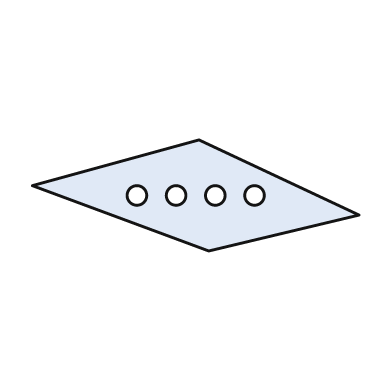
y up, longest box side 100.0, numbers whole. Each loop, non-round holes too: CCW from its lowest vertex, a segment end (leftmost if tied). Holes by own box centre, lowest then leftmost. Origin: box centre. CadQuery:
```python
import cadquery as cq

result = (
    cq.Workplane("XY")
    .moveTo(4.0, -17.0)
    .lineTo(50.0, -6.0)
    .lineTo(1.0, 17.0)
    .lineTo(-50.0, 3.0)
    .close()
    .moveTo(-18.0, 0.0)
    .circle(3.0)
    .moveTo(-6.0, 0.0)
    .circle(3.0)
    .moveTo(6.0, 0.0)
    .circle(3.0)
    .moveTo(18.0, 0.0)
    .circle(3.0)
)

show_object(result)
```